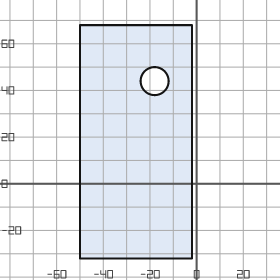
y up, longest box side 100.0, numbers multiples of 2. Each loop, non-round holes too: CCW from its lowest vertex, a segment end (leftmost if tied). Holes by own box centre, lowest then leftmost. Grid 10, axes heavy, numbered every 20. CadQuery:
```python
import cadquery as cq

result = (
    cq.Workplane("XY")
    .moveTo(-50.0, -32.0)
    .lineTo(-2.0, -32.0)
    .lineTo(-2.0, 68.0)
    .lineTo(-50.0, 68.0)
    .close()
    .moveTo(-18.0, 44.0)
    .circle(6.0)
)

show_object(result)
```